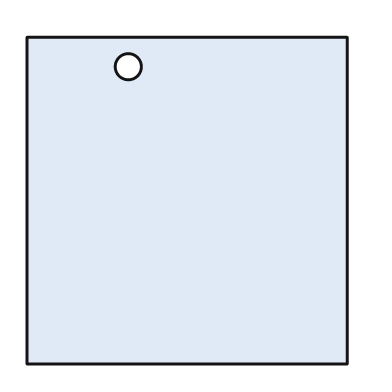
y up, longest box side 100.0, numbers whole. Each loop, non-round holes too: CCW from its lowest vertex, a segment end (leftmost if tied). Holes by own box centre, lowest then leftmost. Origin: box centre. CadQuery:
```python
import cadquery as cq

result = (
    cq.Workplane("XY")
    .moveTo(-49.0, -50.0)
    .lineTo(49.0, -50.0)
    .lineTo(49.0, 50.0)
    .lineTo(-49.0, 50.0)
    .close()
    .moveTo(-18.0, 41.0)
    .circle(4.0)
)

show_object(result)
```